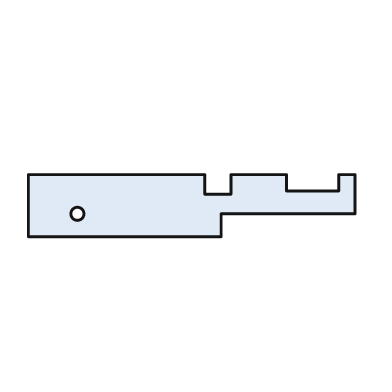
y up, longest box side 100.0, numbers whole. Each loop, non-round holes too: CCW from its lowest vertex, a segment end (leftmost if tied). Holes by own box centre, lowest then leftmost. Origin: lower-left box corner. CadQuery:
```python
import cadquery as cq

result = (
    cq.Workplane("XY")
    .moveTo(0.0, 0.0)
    .lineTo(59.0, 0.0)
    .lineTo(59.0, 7.0)
    .lineTo(100.0, 7.0)
    .lineTo(100.0, 19.0)
    .lineTo(95.0, 19.0)
    .lineTo(95.0, 14.0)
    .lineTo(79.0, 14.0)
    .lineTo(79.0, 19.0)
    .lineTo(62.0, 19.0)
    .lineTo(62.0, 13.0)
    .lineTo(54.0, 13.0)
    .lineTo(54.0, 19.0)
    .lineTo(0.0, 19.0)
    .close()
    .moveTo(15.0, 7.0)
    .circle(2.0)
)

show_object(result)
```